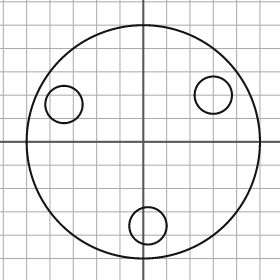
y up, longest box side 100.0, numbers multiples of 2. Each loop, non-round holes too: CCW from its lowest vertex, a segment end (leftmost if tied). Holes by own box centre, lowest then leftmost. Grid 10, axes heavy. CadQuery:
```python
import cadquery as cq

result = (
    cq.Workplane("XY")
    .moveTo(0.0, 0.0)
    .circle(50.0)
    .moveTo(2.0, -36.0)
    .circle(8.0)
    .moveTo(-34.0, 16.0)
    .circle(8.0)
    .moveTo(30.0, 20.0)
    .circle(8.0)
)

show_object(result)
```